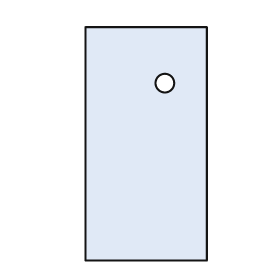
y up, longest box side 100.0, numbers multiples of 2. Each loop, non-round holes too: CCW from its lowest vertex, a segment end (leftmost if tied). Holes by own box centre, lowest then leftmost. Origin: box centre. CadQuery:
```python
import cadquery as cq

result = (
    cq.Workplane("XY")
    .moveTo(-26.0, -50.0)
    .lineTo(26.0, -50.0)
    .lineTo(26.0, 50.0)
    .lineTo(-26.0, 50.0)
    .close()
    .moveTo(8.0, 26.0)
    .circle(4.0)
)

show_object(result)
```